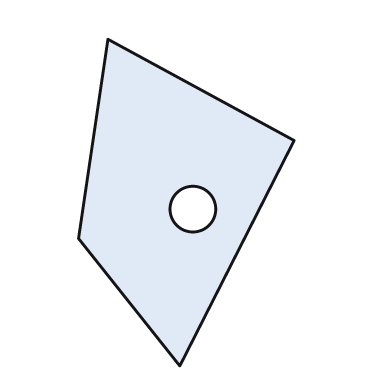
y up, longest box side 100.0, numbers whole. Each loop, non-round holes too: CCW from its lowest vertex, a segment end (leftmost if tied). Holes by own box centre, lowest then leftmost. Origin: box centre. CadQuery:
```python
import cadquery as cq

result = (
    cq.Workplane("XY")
    .moveTo(-2.0, -50.0)
    .lineTo(33.0, 19.0)
    .lineTo(-24.0, 50.0)
    .lineTo(-33.0, -11.0)
    .close()
    .moveTo(2.0, -2.0)
    .circle(7.0)
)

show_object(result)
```